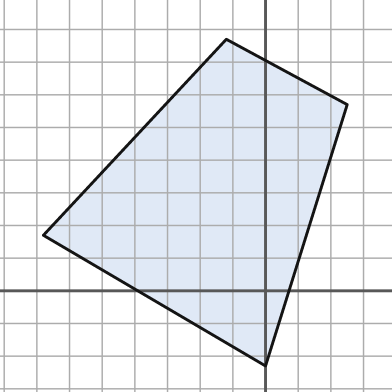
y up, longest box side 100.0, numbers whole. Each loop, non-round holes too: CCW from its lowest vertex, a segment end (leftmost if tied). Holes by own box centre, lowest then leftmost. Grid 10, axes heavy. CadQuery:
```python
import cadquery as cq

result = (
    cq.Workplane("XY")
    .moveTo(0.0, -23.0)
    .lineTo(25.0, 57.0)
    .lineTo(-12.0, 77.0)
    .lineTo(-68.0, 17.0)
    .close()
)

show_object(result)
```